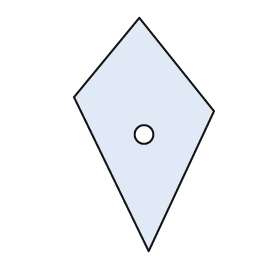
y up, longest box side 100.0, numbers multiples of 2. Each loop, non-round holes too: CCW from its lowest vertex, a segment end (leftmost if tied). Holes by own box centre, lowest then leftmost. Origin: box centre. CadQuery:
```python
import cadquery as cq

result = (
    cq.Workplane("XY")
    .moveTo(2.0, -50.0)
    .lineTo(30.0, 10.0)
    .lineTo(-2.0, 50.0)
    .lineTo(-30.0, 16.0)
    .close()
    .moveTo(0.0, 0.0)
    .circle(4.0)
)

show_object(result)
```